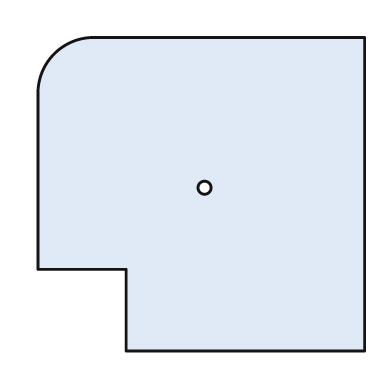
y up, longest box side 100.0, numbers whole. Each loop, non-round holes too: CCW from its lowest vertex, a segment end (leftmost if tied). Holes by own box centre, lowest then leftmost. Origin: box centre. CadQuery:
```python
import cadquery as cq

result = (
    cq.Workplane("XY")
    .moveTo(-23.0, -48.0)
    .lineTo(50.0, -48.0)
    .lineTo(50.0, 48.0)
    .lineTo(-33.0, 48.0)
    .threePointArc((-45.0, 43.0), (-50.0, 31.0))
    .lineTo(-50.0, -23.0)
    .lineTo(-23.0, -23.0)
    .close()
    .moveTo(1.0, 2.0)
    .circle(2.0)
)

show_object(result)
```